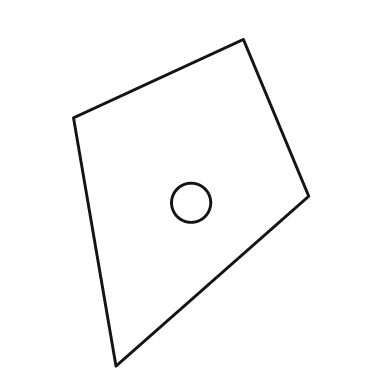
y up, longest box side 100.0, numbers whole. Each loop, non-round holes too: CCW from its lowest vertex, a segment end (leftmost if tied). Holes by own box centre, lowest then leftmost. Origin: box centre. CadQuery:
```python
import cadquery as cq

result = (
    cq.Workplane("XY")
    .moveTo(-23.0, -50.0)
    .lineTo(36.0, 2.0)
    .lineTo(16.0, 50.0)
    .lineTo(-36.0, 26.0)
    .close()
    .moveTo(0.0, 0.0)
    .circle(6.0)
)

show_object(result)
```